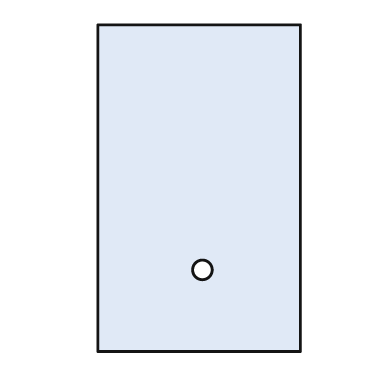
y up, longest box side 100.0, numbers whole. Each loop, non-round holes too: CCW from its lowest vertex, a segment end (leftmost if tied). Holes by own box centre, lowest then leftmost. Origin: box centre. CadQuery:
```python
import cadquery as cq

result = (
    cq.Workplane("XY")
    .moveTo(-31.0, -50.0)
    .lineTo(31.0, -50.0)
    .lineTo(31.0, 50.0)
    .lineTo(-31.0, 50.0)
    .close()
    .moveTo(1.0, -25.0)
    .circle(3.0)
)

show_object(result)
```